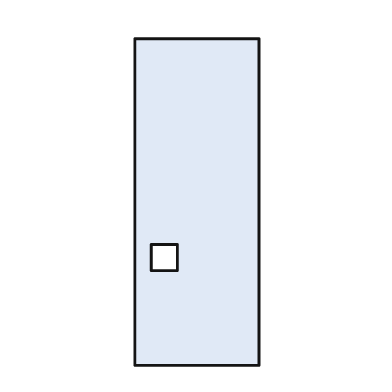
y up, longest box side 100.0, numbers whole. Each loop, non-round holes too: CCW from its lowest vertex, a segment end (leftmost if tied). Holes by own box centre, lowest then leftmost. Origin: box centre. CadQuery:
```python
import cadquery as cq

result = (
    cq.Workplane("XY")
    .moveTo(-19.0, -50.0)
    .lineTo(19.0, -50.0)
    .lineTo(19.0, 50.0)
    .lineTo(-19.0, 50.0)
    .close()
    .moveTo(-14.0, -21.0)
    .lineTo(-6.0, -21.0)
    .lineTo(-6.0, -13.0)
    .lineTo(-14.0, -13.0)
    .close()
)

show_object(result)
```